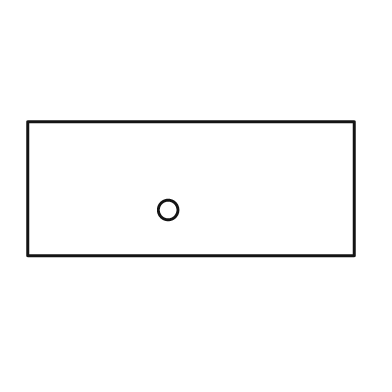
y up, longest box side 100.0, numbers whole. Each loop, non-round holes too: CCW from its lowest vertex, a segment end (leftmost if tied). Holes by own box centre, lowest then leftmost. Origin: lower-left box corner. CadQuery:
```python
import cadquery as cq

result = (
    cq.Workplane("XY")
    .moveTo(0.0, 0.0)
    .lineTo(100.0, 0.0)
    .lineTo(100.0, 41.0)
    .lineTo(0.0, 41.0)
    .close()
    .moveTo(43.0, 14.0)
    .circle(3.0)
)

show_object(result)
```